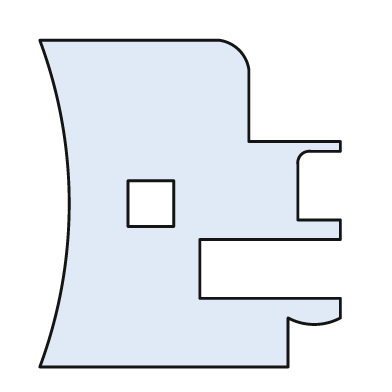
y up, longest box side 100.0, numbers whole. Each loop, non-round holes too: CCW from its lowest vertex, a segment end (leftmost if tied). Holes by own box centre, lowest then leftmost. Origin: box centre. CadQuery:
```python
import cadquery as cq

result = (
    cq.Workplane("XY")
    .moveTo(-46.0, -50.0)
    .lineTo(30.0, -50.0)
    .lineTo(30.0, -35.0)
    .threePointArc((38.0, -37.0), (46.0, -35.0))
    .lineTo(46.0, -29.0)
    .lineTo(3.0, -29.0)
    .lineTo(3.0, -11.0)
    .lineTo(46.0, -11.0)
    .lineTo(46.0, -5.0)
    .lineTo(33.0, -5.0)
    .lineTo(33.0, 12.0)
    .threePointArc((34.0, 15.0), (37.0, 16.0))
    .lineTo(46.0, 16.0)
    .lineTo(46.0, 19.0)
    .lineTo(18.0, 19.0)
    .lineTo(18.0, 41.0)
    .threePointArc((15.0, 47.0), (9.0, 50.0))
    .lineTo(-46.0, 50.0)
    .threePointArc((-37.0, 0.0), (-46.0, -50.0))
    .close()
    .moveTo(-19.0, -7.0)
    .lineTo(-5.0, -7.0)
    .lineTo(-5.0, 7.0)
    .lineTo(-19.0, 7.0)
    .close()
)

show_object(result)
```